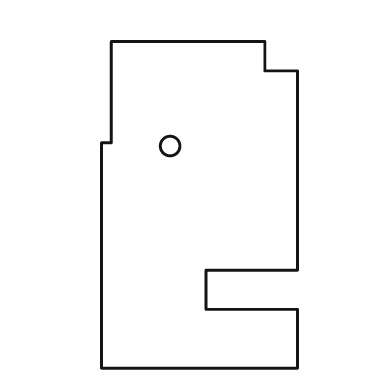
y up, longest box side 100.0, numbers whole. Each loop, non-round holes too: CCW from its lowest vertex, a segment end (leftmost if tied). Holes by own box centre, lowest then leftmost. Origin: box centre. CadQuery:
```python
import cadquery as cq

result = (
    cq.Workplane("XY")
    .moveTo(-30.0, -50.0)
    .lineTo(30.0, -50.0)
    .lineTo(30.0, -32.0)
    .lineTo(2.0, -32.0)
    .lineTo(2.0, -20.0)
    .lineTo(30.0, -20.0)
    .lineTo(30.0, 41.0)
    .lineTo(20.0, 41.0)
    .lineTo(20.0, 50.0)
    .lineTo(-27.0, 50.0)
    .lineTo(-27.0, 19.0)
    .lineTo(-30.0, 19.0)
    .close()
    .moveTo(-9.0, 18.0)
    .circle(3.0)
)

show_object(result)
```